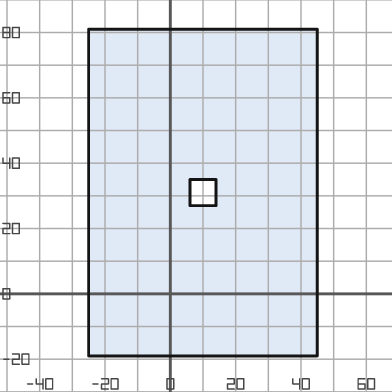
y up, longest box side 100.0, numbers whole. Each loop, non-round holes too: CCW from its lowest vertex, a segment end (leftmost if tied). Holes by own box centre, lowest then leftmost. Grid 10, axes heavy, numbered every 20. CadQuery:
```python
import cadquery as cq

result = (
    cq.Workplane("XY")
    .moveTo(-25.0, -19.0)
    .lineTo(45.0, -19.0)
    .lineTo(45.0, 81.0)
    .lineTo(-25.0, 81.0)
    .close()
    .moveTo(6.0, 27.0)
    .lineTo(14.0, 27.0)
    .lineTo(14.0, 35.0)
    .lineTo(6.0, 35.0)
    .close()
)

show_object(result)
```